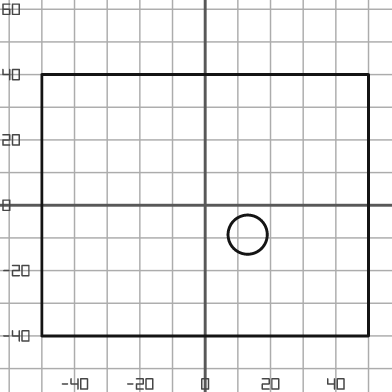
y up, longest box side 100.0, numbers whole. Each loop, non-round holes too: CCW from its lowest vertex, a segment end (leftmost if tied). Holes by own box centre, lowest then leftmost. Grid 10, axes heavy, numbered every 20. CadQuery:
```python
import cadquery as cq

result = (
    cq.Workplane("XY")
    .moveTo(-50.0, -40.0)
    .lineTo(50.0, -40.0)
    .lineTo(50.0, 40.0)
    .lineTo(-50.0, 40.0)
    .close()
    .moveTo(13.0, -9.0)
    .circle(6.0)
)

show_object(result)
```